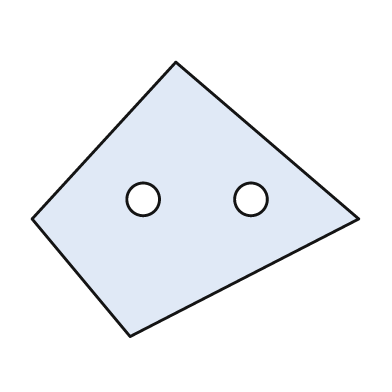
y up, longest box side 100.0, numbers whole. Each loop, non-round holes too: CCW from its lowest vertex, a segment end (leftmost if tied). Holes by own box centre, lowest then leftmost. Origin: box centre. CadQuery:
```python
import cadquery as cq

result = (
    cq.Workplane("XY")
    .moveTo(-20.0, -42.0)
    .lineTo(50.0, -6.0)
    .lineTo(-6.0, 42.0)
    .lineTo(-50.0, -6.0)
    .close()
    .moveTo(-16.0, 0.0)
    .circle(5.0)
    .moveTo(17.0, 0.0)
    .circle(5.0)
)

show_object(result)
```